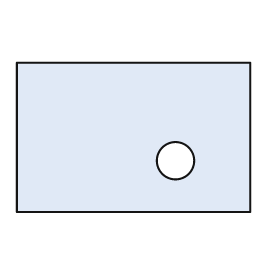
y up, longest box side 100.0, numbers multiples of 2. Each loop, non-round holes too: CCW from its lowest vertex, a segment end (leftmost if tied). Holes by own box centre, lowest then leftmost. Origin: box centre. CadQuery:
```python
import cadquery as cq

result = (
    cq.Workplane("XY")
    .moveTo(-50.0, -32.0)
    .lineTo(50.0, -32.0)
    .lineTo(50.0, 32.0)
    .lineTo(-50.0, 32.0)
    .close()
    .moveTo(18.0, -10.0)
    .circle(8.0)
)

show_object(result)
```